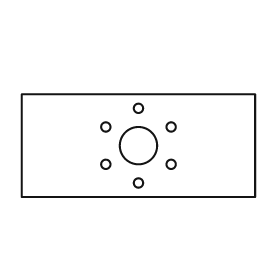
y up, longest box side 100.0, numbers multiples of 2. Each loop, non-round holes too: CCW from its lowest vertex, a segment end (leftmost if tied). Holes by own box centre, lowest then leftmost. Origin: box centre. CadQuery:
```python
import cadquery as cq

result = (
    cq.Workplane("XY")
    .moveTo(-50.0, -22.0)
    .lineTo(50.0, -22.0)
    .lineTo(50.0, 22.0)
    .lineTo(-50.0, 22.0)
    .close()
    .moveTo(0.0, -16.0)
    .circle(2.0)
    .moveTo(-14.0, -8.0)
    .circle(2.0)
    .moveTo(14.0, -8.0)
    .circle(2.0)
    .moveTo(0.0, 0.0)
    .circle(8.0)
    .moveTo(-14.0, 8.0)
    .circle(2.0)
    .moveTo(14.0, 8.0)
    .circle(2.0)
    .moveTo(0.0, 16.0)
    .circle(2.0)
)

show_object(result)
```